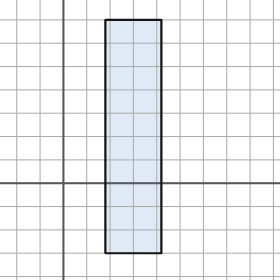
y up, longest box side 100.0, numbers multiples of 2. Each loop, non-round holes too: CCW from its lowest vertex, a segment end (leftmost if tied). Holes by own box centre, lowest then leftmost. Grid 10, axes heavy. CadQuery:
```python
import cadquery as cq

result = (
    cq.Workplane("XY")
    .moveTo(18.0, -30.0)
    .lineTo(42.0, -30.0)
    .lineTo(42.0, 70.0)
    .lineTo(18.0, 70.0)
    .close()
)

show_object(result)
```